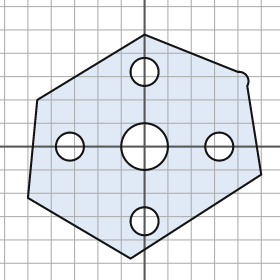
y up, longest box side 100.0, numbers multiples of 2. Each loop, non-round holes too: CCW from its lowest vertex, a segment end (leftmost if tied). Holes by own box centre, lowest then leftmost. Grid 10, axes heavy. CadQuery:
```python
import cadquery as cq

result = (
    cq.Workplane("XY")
    .moveTo(-6.0, -48.0)
    .lineTo(50.0, -12.0)
    .lineTo(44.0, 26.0)
    .threePointArc((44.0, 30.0), (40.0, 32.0))
    .lineTo(0.0, 48.0)
    .lineTo(-46.0, 20.0)
    .lineTo(-50.0, -22.0)
    .close()
    .moveTo(0.0, -32.0)
    .circle(6.0)
    .moveTo(-32.0, 0.0)
    .circle(6.0)
    .moveTo(0.0, 0.0)
    .circle(10.0)
    .moveTo(32.0, 0.0)
    .circle(6.0)
    .moveTo(0.0, 32.0)
    .circle(6.0)
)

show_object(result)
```